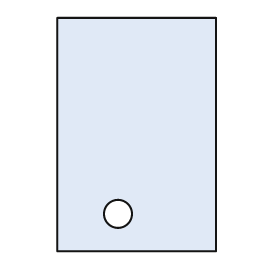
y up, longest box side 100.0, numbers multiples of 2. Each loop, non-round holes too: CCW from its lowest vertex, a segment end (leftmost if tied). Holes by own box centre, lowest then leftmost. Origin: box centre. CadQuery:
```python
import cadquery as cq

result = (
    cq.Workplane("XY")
    .moveTo(-34.0, -50.0)
    .lineTo(34.0, -50.0)
    .lineTo(34.0, 50.0)
    .lineTo(-34.0, 50.0)
    .close()
    .moveTo(-8.0, -34.0)
    .circle(6.0)
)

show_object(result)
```